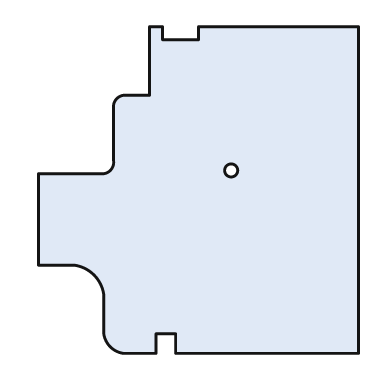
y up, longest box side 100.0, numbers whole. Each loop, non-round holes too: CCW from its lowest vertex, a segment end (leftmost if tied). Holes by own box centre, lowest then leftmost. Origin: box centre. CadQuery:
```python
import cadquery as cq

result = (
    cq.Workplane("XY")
    .moveTo(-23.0, -50.0)
    .lineTo(-13.0, -50.0)
    .lineTo(-13.0, -44.0)
    .lineTo(-7.0, -44.0)
    .lineTo(-7.0, -50.0)
    .lineTo(49.0, -50.0)
    .lineTo(49.0, 50.0)
    .lineTo(0.0, 50.0)
    .lineTo(0.0, 46.0)
    .lineTo(-11.0, 46.0)
    .lineTo(-11.0, 50.0)
    .lineTo(-15.0, 50.0)
    .lineTo(-15.0, 29.0)
    .lineTo(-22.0, 29.0)
    .threePointArc((-25.0, 28.0), (-26.0, 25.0))
    .lineTo(-26.0, 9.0)
    .threePointArc((-27.0, 6.0), (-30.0, 5.0))
    .lineTo(-49.0, 5.0)
    .lineTo(-49.0, -23.0)
    .lineTo(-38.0, -23.0)
    .threePointArc((-32.0, -26.0), (-29.0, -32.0))
    .lineTo(-29.0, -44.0)
    .threePointArc((-27.0, -48.0), (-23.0, -50.0))
    .close()
    .moveTo(10.0, 6.0)
    .circle(2.0)
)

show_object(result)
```